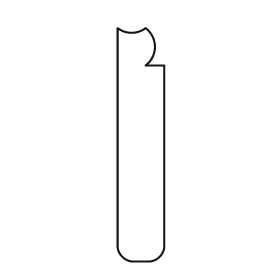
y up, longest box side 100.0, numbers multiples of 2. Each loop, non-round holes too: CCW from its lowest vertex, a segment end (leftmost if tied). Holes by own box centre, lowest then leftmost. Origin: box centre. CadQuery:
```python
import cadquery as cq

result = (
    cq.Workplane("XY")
    .moveTo(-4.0, -50.0)
    .lineTo(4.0, -50.0)
    .threePointArc((8.0, -48.0), (10.0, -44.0))
    .lineTo(10.0, 34.0)
    .lineTo(2.0, 34.0)
    .threePointArc((6.0, 42.0), (2.0, 50.0))
    .threePointArc((-4.0, 48.0), (-10.0, 50.0))
    .lineTo(-10.0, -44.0)
    .threePointArc((-8.0, -48.0), (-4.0, -50.0))
    .close()
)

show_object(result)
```